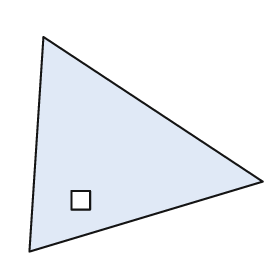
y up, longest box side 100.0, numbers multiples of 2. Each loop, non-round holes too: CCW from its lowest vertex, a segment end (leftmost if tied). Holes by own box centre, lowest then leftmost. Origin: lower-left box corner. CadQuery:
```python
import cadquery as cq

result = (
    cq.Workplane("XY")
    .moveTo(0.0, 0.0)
    .lineTo(100.0, 30.0)
    .lineTo(6.0, 92.0)
    .close()
    .moveTo(18.0, 18.0)
    .lineTo(26.0, 18.0)
    .lineTo(26.0, 26.0)
    .lineTo(18.0, 26.0)
    .close()
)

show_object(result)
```